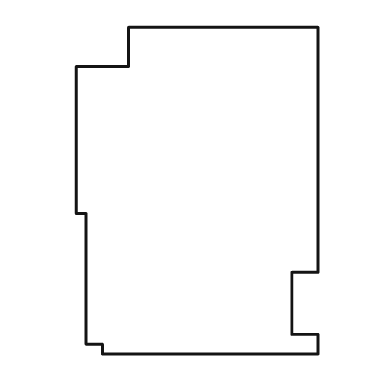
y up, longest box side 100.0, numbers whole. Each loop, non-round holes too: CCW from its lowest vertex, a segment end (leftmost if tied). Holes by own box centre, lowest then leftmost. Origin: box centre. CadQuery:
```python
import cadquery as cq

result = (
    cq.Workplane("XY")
    .moveTo(-29.0, -50.0)
    .lineTo(37.0, -50.0)
    .lineTo(37.0, -44.0)
    .lineTo(29.0, -44.0)
    .lineTo(29.0, -25.0)
    .lineTo(37.0, -25.0)
    .lineTo(37.0, 50.0)
    .lineTo(-21.0, 50.0)
    .lineTo(-21.0, 38.0)
    .lineTo(-37.0, 38.0)
    .lineTo(-37.0, -7.0)
    .lineTo(-34.0, -7.0)
    .lineTo(-34.0, -47.0)
    .lineTo(-29.0, -47.0)
    .close()
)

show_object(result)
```